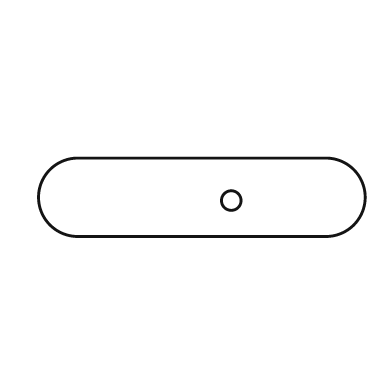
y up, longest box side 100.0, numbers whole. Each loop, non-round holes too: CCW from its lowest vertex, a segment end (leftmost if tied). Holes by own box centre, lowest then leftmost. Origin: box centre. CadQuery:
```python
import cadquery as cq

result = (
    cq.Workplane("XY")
    .moveTo(-38.0, -12.0)
    .lineTo(38.0, -12.0)
    .threePointArc((50.0, 0.0), (38.0, 12.0))
    .lineTo(-38.0, 12.0)
    .threePointArc((-50.0, 0.0), (-38.0, -12.0))
    .close()
    .moveTo(9.0, -1.0)
    .circle(3.0)
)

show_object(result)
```